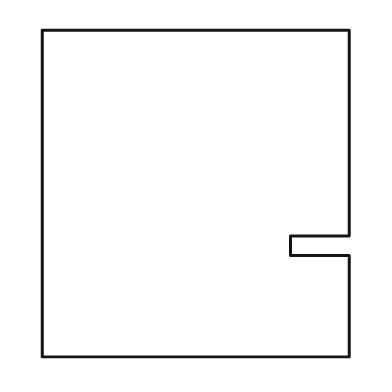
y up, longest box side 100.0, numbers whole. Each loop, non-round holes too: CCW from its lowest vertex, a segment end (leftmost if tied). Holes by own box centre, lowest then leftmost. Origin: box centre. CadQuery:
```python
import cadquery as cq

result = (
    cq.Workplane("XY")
    .moveTo(-47.0, -50.0)
    .lineTo(47.0, -50.0)
    .lineTo(47.0, -19.0)
    .lineTo(29.0, -19.0)
    .lineTo(29.0, -13.0)
    .lineTo(47.0, -13.0)
    .lineTo(47.0, 50.0)
    .lineTo(-47.0, 50.0)
    .close()
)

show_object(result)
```